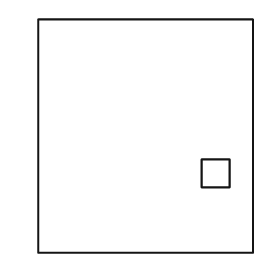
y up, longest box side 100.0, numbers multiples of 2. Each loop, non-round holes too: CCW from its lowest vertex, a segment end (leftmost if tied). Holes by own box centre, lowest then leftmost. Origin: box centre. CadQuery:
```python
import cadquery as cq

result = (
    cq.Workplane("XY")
    .moveTo(-46.0, -50.0)
    .lineTo(46.0, -50.0)
    .lineTo(46.0, 50.0)
    .lineTo(-46.0, 50.0)
    .close()
    .moveTo(24.0, -22.0)
    .lineTo(36.0, -22.0)
    .lineTo(36.0, -10.0)
    .lineTo(24.0, -10.0)
    .close()
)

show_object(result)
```